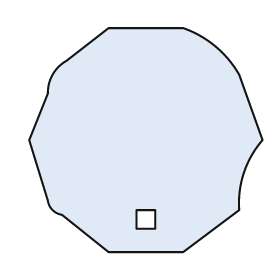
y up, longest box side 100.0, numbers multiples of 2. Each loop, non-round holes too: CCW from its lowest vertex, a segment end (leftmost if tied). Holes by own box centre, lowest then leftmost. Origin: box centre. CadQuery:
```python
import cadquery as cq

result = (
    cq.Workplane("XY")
    .moveTo(-16.0, -48.0)
    .lineTo(16.0, -48.0)
    .lineTo(40.0, -30.0)
    .threePointArc((42.0, -14.0), (50.0, 0.0))
    .lineTo(40.0, 28.0)
    .threePointArc((30.0, 40.0), (16.0, 48.0))
    .lineTo(-16.0, 48.0)
    .lineTo(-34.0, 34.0)
    .threePointArc((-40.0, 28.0), (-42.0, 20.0))
    .lineTo(-50.0, 0.0)
    .lineTo(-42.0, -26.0)
    .threePointArc((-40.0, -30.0), (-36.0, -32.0))
    .close()
    .moveTo(-4.0, -38.0)
    .lineTo(4.0, -38.0)
    .lineTo(4.0, -30.0)
    .lineTo(-4.0, -30.0)
    .close()
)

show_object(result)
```